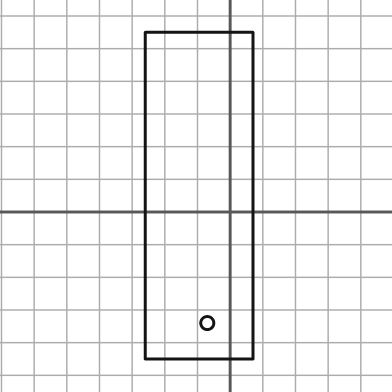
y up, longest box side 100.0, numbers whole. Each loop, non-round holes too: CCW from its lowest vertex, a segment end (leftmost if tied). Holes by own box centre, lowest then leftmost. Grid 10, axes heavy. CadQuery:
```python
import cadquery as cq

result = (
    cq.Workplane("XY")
    .moveTo(-26.0, -45.0)
    .lineTo(7.0, -45.0)
    .lineTo(7.0, 55.0)
    .lineTo(-26.0, 55.0)
    .close()
    .moveTo(-7.0, -34.0)
    .circle(2.0)
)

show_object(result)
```